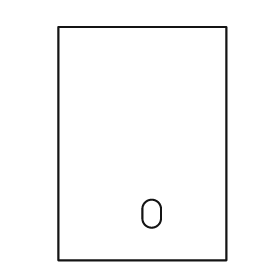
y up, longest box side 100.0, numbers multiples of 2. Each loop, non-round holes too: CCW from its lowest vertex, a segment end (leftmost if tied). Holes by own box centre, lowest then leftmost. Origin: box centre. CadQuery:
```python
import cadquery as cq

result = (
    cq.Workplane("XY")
    .moveTo(-36.0, -50.0)
    .lineTo(36.0, -50.0)
    .lineTo(36.0, 50.0)
    .lineTo(-36.0, 50.0)
    .close()
    .moveTo(0.0, -32.0)
    .threePointArc((4.0, -36.0), (8.0, -32.0))
    .lineTo(8.0, -28.0)
    .threePointArc((4.0, -24.0), (0.0, -28.0))
    .close()
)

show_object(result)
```